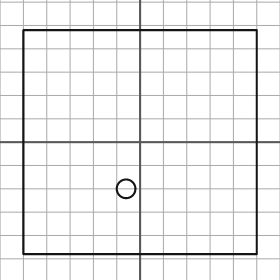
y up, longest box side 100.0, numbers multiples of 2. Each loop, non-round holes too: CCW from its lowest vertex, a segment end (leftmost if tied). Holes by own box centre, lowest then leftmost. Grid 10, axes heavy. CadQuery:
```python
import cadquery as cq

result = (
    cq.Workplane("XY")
    .moveTo(-50.0, -48.0)
    .lineTo(50.0, -48.0)
    .lineTo(50.0, 48.0)
    .lineTo(-50.0, 48.0)
    .close()
    .moveTo(-6.0, -20.0)
    .circle(4.0)
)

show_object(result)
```